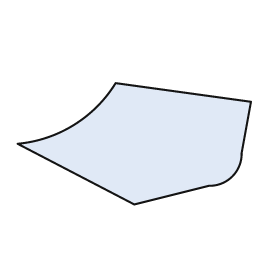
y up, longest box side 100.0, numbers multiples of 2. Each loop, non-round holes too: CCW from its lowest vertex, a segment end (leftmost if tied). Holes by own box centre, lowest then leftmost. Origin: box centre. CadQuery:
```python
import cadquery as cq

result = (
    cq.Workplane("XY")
    .moveTo(0.0, -26.0)
    .lineTo(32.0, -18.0)
    .threePointArc((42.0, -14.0), (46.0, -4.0))
    .lineTo(50.0, 18.0)
    .lineTo(-8.0, 26.0)
    .threePointArc((-26.0, 8.0), (-50.0, 0.0))
    .close()
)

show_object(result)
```